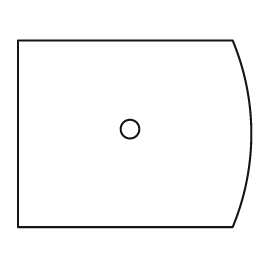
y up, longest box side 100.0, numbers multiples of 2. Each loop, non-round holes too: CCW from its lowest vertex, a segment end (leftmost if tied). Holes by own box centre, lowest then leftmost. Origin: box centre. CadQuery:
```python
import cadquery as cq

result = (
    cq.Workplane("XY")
    .moveTo(-50.0, -40.0)
    .lineTo(42.0, -40.0)
    .threePointArc((50.0, 0.0), (42.0, 40.0))
    .lineTo(-50.0, 40.0)
    .close()
    .moveTo(-2.0, 2.0)
    .circle(4.0)
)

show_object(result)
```